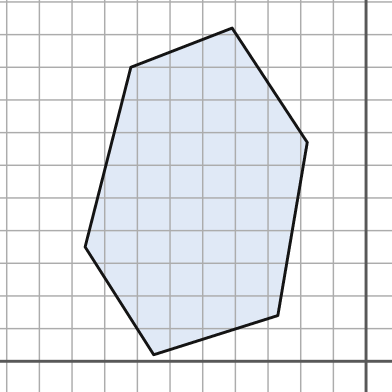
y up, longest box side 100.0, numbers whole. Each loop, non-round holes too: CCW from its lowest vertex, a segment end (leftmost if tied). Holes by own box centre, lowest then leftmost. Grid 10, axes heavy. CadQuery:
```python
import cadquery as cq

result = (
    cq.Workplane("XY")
    .moveTo(-65.0, 2.0)
    .lineTo(-27.0, 14.0)
    .lineTo(-18.0, 67.0)
    .lineTo(-41.0, 102.0)
    .lineTo(-72.0, 90.0)
    .lineTo(-86.0, 35.0)
    .close()
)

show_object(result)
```